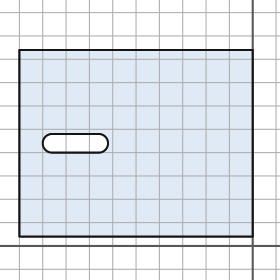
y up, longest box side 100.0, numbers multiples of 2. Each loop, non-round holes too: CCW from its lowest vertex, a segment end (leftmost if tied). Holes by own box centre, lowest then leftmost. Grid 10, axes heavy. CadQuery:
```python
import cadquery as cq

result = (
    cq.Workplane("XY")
    .moveTo(-100.0, 4.0)
    .lineTo(0.0, 4.0)
    .lineTo(0.0, 84.0)
    .lineTo(-100.0, 84.0)
    .close()
    .moveTo(-86.0, 40.0)
    .lineTo(-66.0, 40.0)
    .threePointArc((-62.0, 44.0), (-66.0, 48.0))
    .lineTo(-86.0, 48.0)
    .threePointArc((-90.0, 44.0), (-86.0, 40.0))
    .close()
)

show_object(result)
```